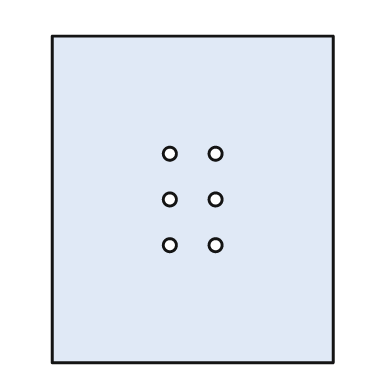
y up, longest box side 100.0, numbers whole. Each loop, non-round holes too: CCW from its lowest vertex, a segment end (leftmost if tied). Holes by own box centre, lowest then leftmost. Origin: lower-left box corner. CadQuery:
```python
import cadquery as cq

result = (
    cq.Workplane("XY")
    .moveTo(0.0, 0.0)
    .lineTo(86.0, 0.0)
    .lineTo(86.0, 100.0)
    .lineTo(0.0, 100.0)
    .close()
    .moveTo(36.0, 36.0)
    .circle(2.0)
    .moveTo(50.0, 36.0)
    .circle(2.0)
    .moveTo(36.0, 50.0)
    .circle(2.0)
    .moveTo(50.0, 50.0)
    .circle(2.0)
    .moveTo(36.0, 64.0)
    .circle(2.0)
    .moveTo(50.0, 64.0)
    .circle(2.0)
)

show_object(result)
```